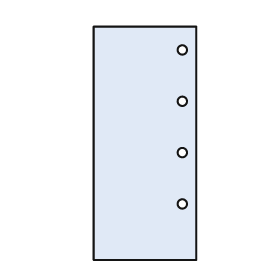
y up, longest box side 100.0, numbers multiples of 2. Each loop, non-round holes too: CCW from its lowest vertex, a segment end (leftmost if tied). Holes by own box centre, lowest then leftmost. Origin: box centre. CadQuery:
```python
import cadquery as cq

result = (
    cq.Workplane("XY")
    .moveTo(-22.0, -50.0)
    .lineTo(22.0, -50.0)
    .lineTo(22.0, 50.0)
    .lineTo(-22.0, 50.0)
    .close()
    .moveTo(16.0, -26.0)
    .circle(2.0)
    .moveTo(16.0, -4.0)
    .circle(2.0)
    .moveTo(16.0, 18.0)
    .circle(2.0)
    .moveTo(16.0, 40.0)
    .circle(2.0)
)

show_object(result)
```